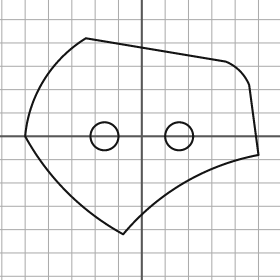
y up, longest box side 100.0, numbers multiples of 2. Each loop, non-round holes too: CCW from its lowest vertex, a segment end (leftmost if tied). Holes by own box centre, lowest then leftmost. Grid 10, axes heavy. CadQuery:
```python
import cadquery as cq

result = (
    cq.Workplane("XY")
    .moveTo(-8.0, -42.0)
    .threePointArc((18.0, -20.0), (50.0, -8.0))
    .lineTo(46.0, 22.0)
    .threePointArc((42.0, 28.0), (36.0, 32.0))
    .lineTo(-24.0, 42.0)
    .threePointArc((-42.0, 24.0), (-50.0, 0.0))
    .threePointArc((-32.0, -24.0), (-8.0, -42.0))
    .close()
    .moveTo(-16.0, 0.0)
    .circle(6.0)
    .moveTo(16.0, 0.0)
    .circle(6.0)
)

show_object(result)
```